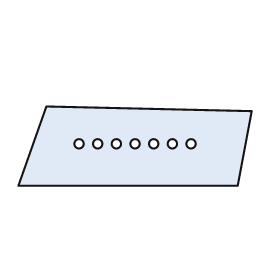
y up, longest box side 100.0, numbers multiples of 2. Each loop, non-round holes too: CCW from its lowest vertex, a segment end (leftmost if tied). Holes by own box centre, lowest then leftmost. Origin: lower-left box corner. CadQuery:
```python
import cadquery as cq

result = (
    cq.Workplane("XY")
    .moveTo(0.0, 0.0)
    .lineTo(94.0, 0.0)
    .lineTo(100.0, 32.0)
    .lineTo(12.0, 34.0)
    .close()
    .moveTo(26.0, 18.0)
    .circle(2.0)
    .moveTo(34.0, 18.0)
    .circle(2.0)
    .moveTo(42.0, 18.0)
    .circle(2.0)
    .moveTo(50.0, 18.0)
    .circle(2.0)
    .moveTo(58.0, 18.0)
    .circle(2.0)
    .moveTo(66.0, 18.0)
    .circle(2.0)
    .moveTo(74.0, 18.0)
    .circle(2.0)
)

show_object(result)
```